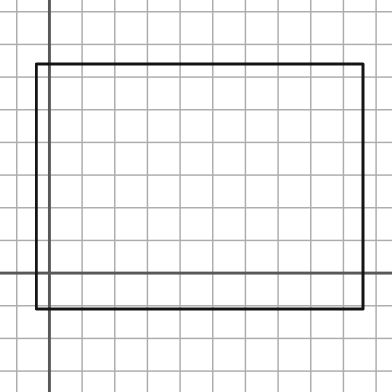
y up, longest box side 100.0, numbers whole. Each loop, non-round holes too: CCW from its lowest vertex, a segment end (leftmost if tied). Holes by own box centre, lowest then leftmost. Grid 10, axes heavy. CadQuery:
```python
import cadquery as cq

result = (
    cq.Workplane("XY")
    .moveTo(-4.0, -11.0)
    .lineTo(96.0, -11.0)
    .lineTo(96.0, 64.0)
    .lineTo(-4.0, 64.0)
    .close()
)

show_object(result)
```